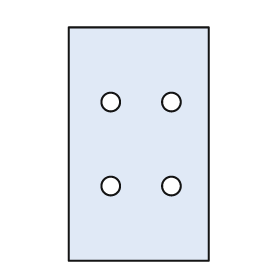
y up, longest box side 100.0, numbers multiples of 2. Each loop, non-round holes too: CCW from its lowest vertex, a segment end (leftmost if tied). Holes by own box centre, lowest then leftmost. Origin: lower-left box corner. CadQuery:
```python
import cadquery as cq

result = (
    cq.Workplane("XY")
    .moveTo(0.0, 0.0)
    .lineTo(60.0, 0.0)
    .lineTo(60.0, 100.0)
    .lineTo(0.0, 100.0)
    .close()
    .moveTo(18.0, 32.0)
    .circle(4.0)
    .moveTo(44.0, 32.0)
    .circle(4.0)
    .moveTo(18.0, 68.0)
    .circle(4.0)
    .moveTo(44.0, 68.0)
    .circle(4.0)
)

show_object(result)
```